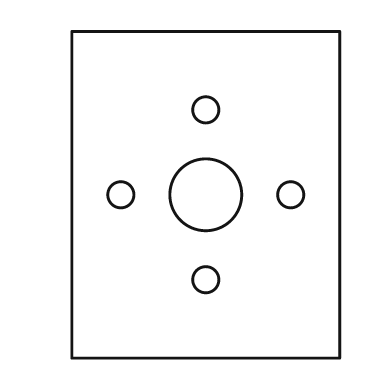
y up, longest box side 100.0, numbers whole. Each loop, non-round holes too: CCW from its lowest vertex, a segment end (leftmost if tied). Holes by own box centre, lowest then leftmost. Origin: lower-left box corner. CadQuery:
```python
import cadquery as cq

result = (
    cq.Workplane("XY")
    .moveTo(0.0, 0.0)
    .lineTo(82.0, 0.0)
    .lineTo(82.0, 100.0)
    .lineTo(0.0, 100.0)
    .close()
    .moveTo(41.0, 24.0)
    .circle(4.0)
    .moveTo(15.0, 50.0)
    .circle(4.0)
    .moveTo(41.0, 50.0)
    .circle(11.0)
    .moveTo(67.0, 50.0)
    .circle(4.0)
    .moveTo(41.0, 76.0)
    .circle(4.0)
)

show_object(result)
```